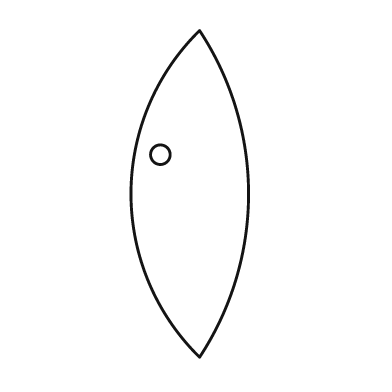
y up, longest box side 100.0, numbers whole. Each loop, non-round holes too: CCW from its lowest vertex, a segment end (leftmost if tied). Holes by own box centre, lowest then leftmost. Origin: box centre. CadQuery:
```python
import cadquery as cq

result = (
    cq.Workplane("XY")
    .moveTo(3.0, -50.0)
    .threePointArc((18.0, 0.0), (3.0, 50.0))
    .threePointArc((-18.0, 0.0), (3.0, -50.0))
    .close()
    .moveTo(-9.0, 12.0)
    .circle(3.0)
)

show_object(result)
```